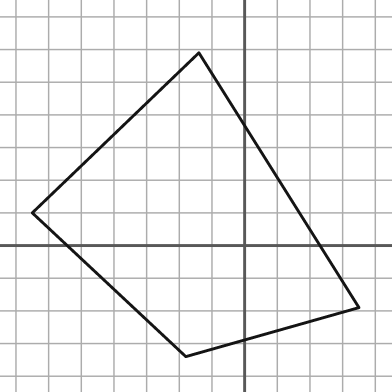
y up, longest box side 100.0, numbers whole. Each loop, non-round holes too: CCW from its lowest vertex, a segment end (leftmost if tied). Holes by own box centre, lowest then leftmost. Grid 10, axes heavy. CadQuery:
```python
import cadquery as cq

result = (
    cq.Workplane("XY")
    .moveTo(-18.0, -34.0)
    .lineTo(35.0, -19.0)
    .lineTo(-14.0, 59.0)
    .lineTo(-65.0, 10.0)
    .close()
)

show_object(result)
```